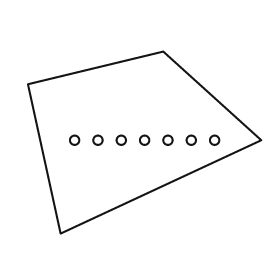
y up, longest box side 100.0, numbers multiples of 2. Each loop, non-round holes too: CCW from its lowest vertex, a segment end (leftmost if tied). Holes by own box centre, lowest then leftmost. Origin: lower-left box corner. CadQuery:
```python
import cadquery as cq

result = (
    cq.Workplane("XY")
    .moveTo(14.0, 0.0)
    .lineTo(100.0, 40.0)
    .lineTo(58.0, 78.0)
    .lineTo(0.0, 64.0)
    .close()
    .moveTo(20.0, 40.0)
    .circle(2.0)
    .moveTo(30.0, 40.0)
    .circle(2.0)
    .moveTo(40.0, 40.0)
    .circle(2.0)
    .moveTo(50.0, 40.0)
    .circle(2.0)
    .moveTo(60.0, 40.0)
    .circle(2.0)
    .moveTo(70.0, 40.0)
    .circle(2.0)
    .moveTo(80.0, 40.0)
    .circle(2.0)
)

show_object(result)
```